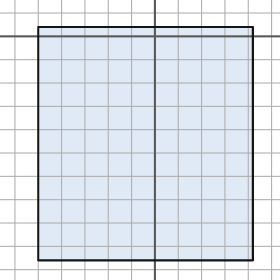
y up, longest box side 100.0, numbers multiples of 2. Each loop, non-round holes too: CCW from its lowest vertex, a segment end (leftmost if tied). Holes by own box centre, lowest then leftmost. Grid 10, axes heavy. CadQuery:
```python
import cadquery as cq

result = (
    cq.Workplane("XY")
    .moveTo(-50.0, -96.0)
    .lineTo(42.0, -96.0)
    .lineTo(42.0, 4.0)
    .lineTo(-50.0, 4.0)
    .close()
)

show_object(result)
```